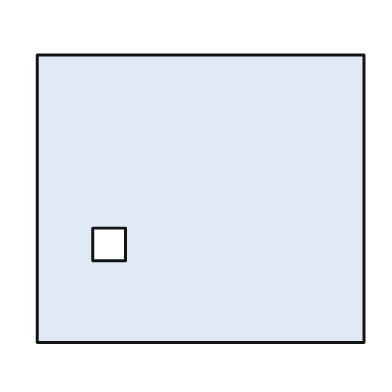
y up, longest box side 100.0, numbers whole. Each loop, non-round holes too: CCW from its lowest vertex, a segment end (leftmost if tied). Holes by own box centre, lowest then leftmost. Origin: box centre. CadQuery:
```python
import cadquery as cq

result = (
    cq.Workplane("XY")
    .moveTo(-50.0, -44.0)
    .lineTo(50.0, -44.0)
    .lineTo(50.0, 44.0)
    .lineTo(-50.0, 44.0)
    .close()
    .moveTo(-33.0, -19.0)
    .lineTo(-23.0, -19.0)
    .lineTo(-23.0, -9.0)
    .lineTo(-33.0, -9.0)
    .close()
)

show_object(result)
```